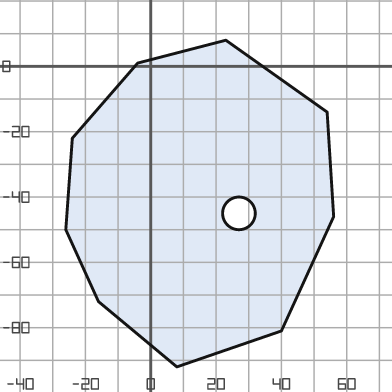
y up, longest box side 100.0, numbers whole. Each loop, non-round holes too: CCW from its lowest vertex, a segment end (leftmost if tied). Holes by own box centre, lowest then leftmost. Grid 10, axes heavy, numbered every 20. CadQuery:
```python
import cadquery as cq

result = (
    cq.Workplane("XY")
    .moveTo(8.0, -92.0)
    .lineTo(40.0, -81.0)
    .lineTo(56.0, -46.0)
    .lineTo(54.0, -14.0)
    .lineTo(23.0, 8.0)
    .lineTo(-4.0, 1.0)
    .lineTo(-24.0, -22.0)
    .lineTo(-26.0, -50.0)
    .lineTo(-16.0, -72.0)
    .close()
    .moveTo(27.0, -45.0)
    .circle(5.0)
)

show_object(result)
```